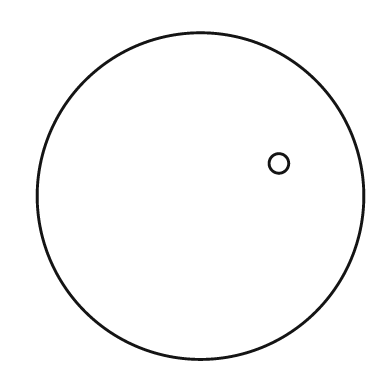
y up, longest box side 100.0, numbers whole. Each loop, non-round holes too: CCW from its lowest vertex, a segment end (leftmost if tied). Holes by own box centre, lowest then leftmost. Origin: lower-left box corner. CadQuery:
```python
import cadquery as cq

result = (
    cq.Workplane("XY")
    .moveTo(50.0, 50.0)
    .circle(50.0)
    .moveTo(74.0, 60.0)
    .circle(3.0)
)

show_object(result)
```